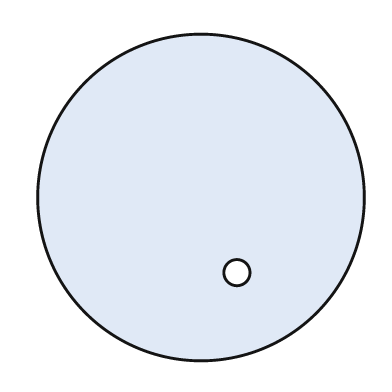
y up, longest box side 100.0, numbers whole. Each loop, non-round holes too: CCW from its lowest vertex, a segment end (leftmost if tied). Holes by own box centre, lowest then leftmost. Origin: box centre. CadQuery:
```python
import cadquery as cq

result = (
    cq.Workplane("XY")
    .moveTo(0.0, 0.0)
    .circle(50.0)
    .moveTo(11.0, -23.0)
    .circle(4.0)
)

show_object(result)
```